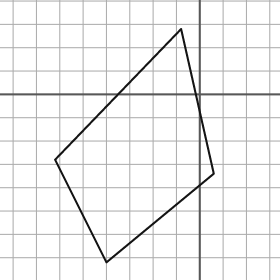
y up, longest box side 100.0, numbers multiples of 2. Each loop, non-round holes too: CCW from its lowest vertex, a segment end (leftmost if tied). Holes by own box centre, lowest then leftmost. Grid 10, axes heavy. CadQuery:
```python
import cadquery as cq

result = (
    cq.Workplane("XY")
    .moveTo(-40.0, -72.0)
    .lineTo(6.0, -34.0)
    .lineTo(-8.0, 28.0)
    .lineTo(-62.0, -28.0)
    .close()
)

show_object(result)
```